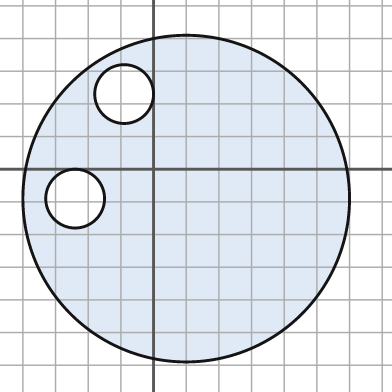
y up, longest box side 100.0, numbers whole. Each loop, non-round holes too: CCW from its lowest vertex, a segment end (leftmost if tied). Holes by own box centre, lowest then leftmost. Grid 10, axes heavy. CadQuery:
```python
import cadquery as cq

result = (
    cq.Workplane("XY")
    .moveTo(10.0, -9.0)
    .circle(50.0)
    .moveTo(-24.0, -9.0)
    .circle(9.0)
    .moveTo(-9.0, 23.0)
    .circle(9.0)
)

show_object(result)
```